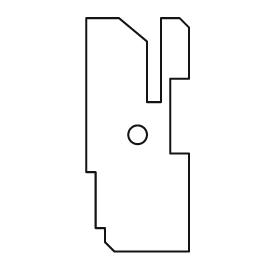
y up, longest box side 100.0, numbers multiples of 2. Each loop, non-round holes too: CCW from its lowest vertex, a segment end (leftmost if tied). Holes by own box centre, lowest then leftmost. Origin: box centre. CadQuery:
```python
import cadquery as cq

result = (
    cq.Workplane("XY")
    .moveTo(-10.0, -50.0)
    .lineTo(22.0, -50.0)
    .lineTo(22.0, -8.0)
    .lineTo(14.0, -8.0)
    .lineTo(14.0, 24.0)
    .lineTo(22.0, 24.0)
    .lineTo(22.0, 46.0)
    .lineTo(18.0, 50.0)
    .lineTo(10.0, 50.0)
    .lineTo(10.0, 14.0)
    .lineTo(4.0, 14.0)
    .lineTo(4.0, 40.0)
    .lineTo(-8.0, 50.0)
    .lineTo(-22.0, 50.0)
    .lineTo(-22.0, -16.0)
    .lineTo(-18.0, -16.0)
    .lineTo(-18.0, -40.0)
    .lineTo(-14.0, -40.0)
    .lineTo(-14.0, -46.0)
    .close()
    .moveTo(0.0, 0.0)
    .circle(4.0)
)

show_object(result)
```